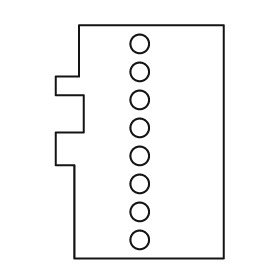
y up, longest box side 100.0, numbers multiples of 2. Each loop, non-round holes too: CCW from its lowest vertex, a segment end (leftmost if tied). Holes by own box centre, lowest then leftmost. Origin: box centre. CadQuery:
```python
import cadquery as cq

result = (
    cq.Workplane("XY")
    .moveTo(-28.0, -50.0)
    .lineTo(36.0, -50.0)
    .lineTo(36.0, 50.0)
    .lineTo(-26.0, 50.0)
    .lineTo(-26.0, 28.0)
    .lineTo(-36.0, 28.0)
    .lineTo(-36.0, 20.0)
    .lineTo(-24.0, 20.0)
    .lineTo(-24.0, 4.0)
    .lineTo(-36.0, 4.0)
    .lineTo(-36.0, -10.0)
    .lineTo(-28.0, -10.0)
    .close()
    .moveTo(0.0, -42.0)
    .circle(4.0)
    .moveTo(0.0, -30.0)
    .circle(4.0)
    .moveTo(0.0, -18.0)
    .circle(4.0)
    .moveTo(0.0, -6.0)
    .circle(4.0)
    .moveTo(0.0, 6.0)
    .circle(4.0)
    .moveTo(0.0, 18.0)
    .circle(4.0)
    .moveTo(0.0, 30.0)
    .circle(4.0)
    .moveTo(0.0, 42.0)
    .circle(4.0)
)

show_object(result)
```